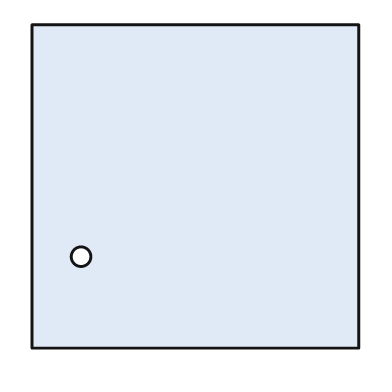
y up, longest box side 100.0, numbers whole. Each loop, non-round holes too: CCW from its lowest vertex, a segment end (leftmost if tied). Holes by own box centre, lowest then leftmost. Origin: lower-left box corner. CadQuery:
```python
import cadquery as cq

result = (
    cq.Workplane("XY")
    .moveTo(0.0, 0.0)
    .lineTo(100.0, 0.0)
    .lineTo(100.0, 99.0)
    .lineTo(0.0, 99.0)
    .close()
    .moveTo(15.0, 28.0)
    .circle(3.0)
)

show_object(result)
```